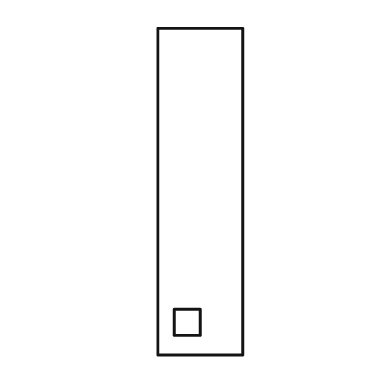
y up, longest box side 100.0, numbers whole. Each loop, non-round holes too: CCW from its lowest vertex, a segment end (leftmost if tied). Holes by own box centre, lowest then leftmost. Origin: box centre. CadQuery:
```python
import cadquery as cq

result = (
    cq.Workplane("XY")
    .moveTo(-13.0, -50.0)
    .lineTo(13.0, -50.0)
    .lineTo(13.0, 50.0)
    .lineTo(-13.0, 50.0)
    .close()
    .moveTo(-8.0, -44.0)
    .lineTo(0.0, -44.0)
    .lineTo(0.0, -36.0)
    .lineTo(-8.0, -36.0)
    .close()
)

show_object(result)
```